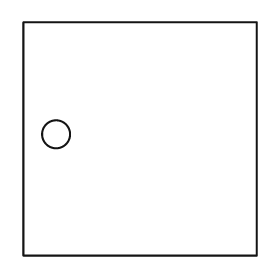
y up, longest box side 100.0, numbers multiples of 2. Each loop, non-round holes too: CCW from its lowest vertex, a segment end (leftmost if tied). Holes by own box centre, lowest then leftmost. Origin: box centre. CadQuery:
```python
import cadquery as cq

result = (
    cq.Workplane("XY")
    .moveTo(-50.0, -50.0)
    .lineTo(50.0, -50.0)
    .lineTo(50.0, 50.0)
    .lineTo(-50.0, 50.0)
    .close()
    .moveTo(-36.0, 2.0)
    .circle(6.0)
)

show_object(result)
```